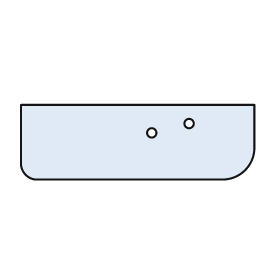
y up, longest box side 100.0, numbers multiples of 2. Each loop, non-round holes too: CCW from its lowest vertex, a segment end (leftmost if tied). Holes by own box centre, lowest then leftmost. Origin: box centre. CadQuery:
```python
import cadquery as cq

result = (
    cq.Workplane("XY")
    .moveTo(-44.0, -16.0)
    .lineTo(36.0, -16.0)
    .threePointArc((46.0, -12.0), (50.0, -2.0))
    .lineTo(50.0, 16.0)
    .lineTo(-50.0, 16.0)
    .lineTo(-50.0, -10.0)
    .threePointArc((-48.0, -14.0), (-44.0, -16.0))
    .close()
    .moveTo(6.0, 4.0)
    .circle(2.0)
    .moveTo(22.0, 8.0)
    .circle(2.0)
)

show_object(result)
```